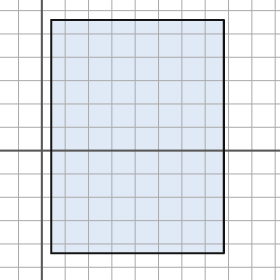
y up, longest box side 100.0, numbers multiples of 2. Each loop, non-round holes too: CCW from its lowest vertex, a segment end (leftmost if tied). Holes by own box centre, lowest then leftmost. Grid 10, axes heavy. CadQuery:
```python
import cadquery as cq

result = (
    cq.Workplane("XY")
    .moveTo(4.0, -44.0)
    .lineTo(78.0, -44.0)
    .lineTo(78.0, 56.0)
    .lineTo(4.0, 56.0)
    .close()
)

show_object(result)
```